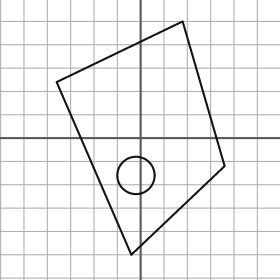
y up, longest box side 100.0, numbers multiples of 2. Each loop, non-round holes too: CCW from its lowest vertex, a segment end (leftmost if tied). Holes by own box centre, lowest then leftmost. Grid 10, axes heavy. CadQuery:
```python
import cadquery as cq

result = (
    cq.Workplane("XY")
    .moveTo(-4.0, -50.0)
    .lineTo(36.0, -12.0)
    .lineTo(18.0, 50.0)
    .lineTo(-36.0, 24.0)
    .close()
    .moveTo(-2.0, -16.0)
    .circle(8.0)
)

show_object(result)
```